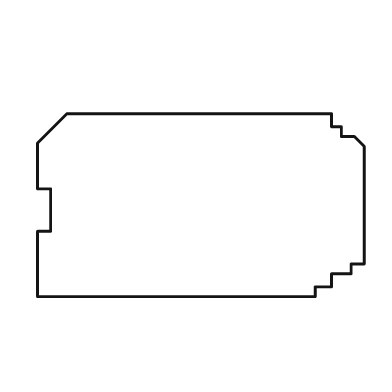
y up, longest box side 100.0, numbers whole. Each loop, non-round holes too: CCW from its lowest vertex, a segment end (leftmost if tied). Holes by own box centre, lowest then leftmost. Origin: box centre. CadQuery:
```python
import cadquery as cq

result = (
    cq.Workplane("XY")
    .moveTo(-50.0, -28.0)
    .lineTo(35.0, -28.0)
    .lineTo(35.0, -25.0)
    .lineTo(40.0, -25.0)
    .lineTo(40.0, -21.0)
    .lineTo(46.0, -21.0)
    .lineTo(46.0, -18.0)
    .lineTo(50.0, -18.0)
    .lineTo(50.0, 18.0)
    .lineTo(47.0, 21.0)
    .lineTo(43.0, 21.0)
    .lineTo(43.0, 24.0)
    .lineTo(40.0, 24.0)
    .lineTo(40.0, 28.0)
    .lineTo(-41.0, 28.0)
    .lineTo(-50.0, 19.0)
    .lineTo(-50.0, 5.0)
    .lineTo(-46.0, 5.0)
    .lineTo(-46.0, -8.0)
    .lineTo(-50.0, -8.0)
    .close()
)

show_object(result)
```